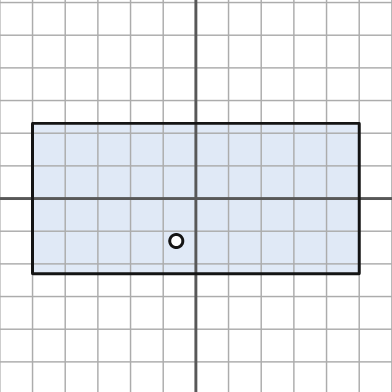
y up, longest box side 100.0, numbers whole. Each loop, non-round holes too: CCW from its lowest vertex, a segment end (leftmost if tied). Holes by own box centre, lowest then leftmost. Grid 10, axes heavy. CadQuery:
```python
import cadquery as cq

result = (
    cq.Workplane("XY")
    .moveTo(-50.0, -23.0)
    .lineTo(50.0, -23.0)
    .lineTo(50.0, 23.0)
    .lineTo(-50.0, 23.0)
    .close()
    .moveTo(-6.0, -13.0)
    .circle(2.0)
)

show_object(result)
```